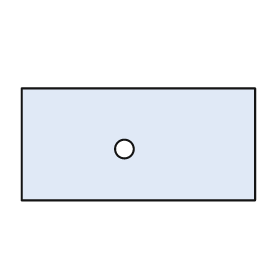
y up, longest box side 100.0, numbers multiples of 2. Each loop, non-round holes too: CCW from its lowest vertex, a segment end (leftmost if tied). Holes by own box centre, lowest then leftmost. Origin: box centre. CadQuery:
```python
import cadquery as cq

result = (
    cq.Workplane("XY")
    .moveTo(-50.0, -24.0)
    .lineTo(50.0, -24.0)
    .lineTo(50.0, 24.0)
    .lineTo(-50.0, 24.0)
    .close()
    .moveTo(-6.0, -2.0)
    .circle(4.0)
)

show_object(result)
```